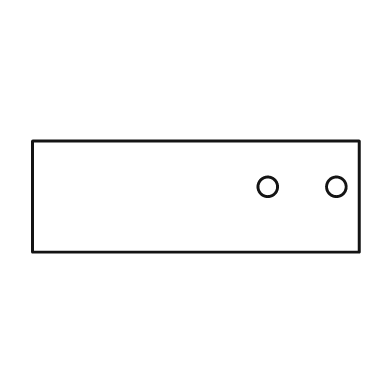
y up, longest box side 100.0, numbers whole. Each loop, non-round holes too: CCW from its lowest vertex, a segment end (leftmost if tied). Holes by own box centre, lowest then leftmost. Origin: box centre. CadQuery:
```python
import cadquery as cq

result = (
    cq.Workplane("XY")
    .moveTo(-50.0, -17.0)
    .lineTo(50.0, -17.0)
    .lineTo(50.0, 17.0)
    .lineTo(-50.0, 17.0)
    .close()
    .moveTo(22.0, 3.0)
    .circle(3.0)
    .moveTo(43.0, 3.0)
    .circle(3.0)
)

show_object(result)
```